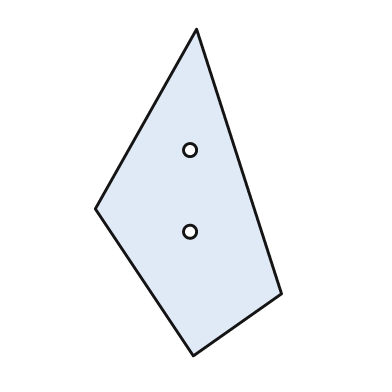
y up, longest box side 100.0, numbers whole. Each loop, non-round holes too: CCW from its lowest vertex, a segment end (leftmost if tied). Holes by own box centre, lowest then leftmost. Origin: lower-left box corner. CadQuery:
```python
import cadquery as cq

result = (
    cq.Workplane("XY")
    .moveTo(30.0, 0.0)
    .lineTo(57.0, 19.0)
    .lineTo(31.0, 100.0)
    .lineTo(0.0, 45.0)
    .close()
    .moveTo(29.0, 38.0)
    .circle(2.0)
    .moveTo(29.0, 63.0)
    .circle(2.0)
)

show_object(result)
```